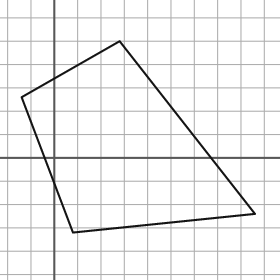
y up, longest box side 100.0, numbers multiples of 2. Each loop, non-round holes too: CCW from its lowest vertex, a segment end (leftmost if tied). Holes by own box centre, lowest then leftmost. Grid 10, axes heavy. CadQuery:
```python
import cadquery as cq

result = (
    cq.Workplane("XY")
    .moveTo(8.0, -32.0)
    .lineTo(86.0, -24.0)
    .lineTo(28.0, 50.0)
    .lineTo(-14.0, 26.0)
    .close()
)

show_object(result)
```